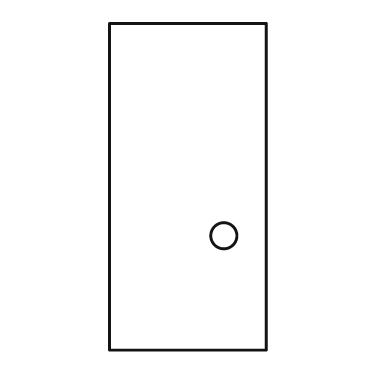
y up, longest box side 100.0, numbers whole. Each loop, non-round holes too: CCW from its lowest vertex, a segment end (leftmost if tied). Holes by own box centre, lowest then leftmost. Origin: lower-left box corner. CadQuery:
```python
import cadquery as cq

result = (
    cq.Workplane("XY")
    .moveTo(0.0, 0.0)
    .lineTo(48.0, 0.0)
    .lineTo(48.0, 100.0)
    .lineTo(0.0, 100.0)
    .close()
    .moveTo(35.0, 35.0)
    .circle(4.0)
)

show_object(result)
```